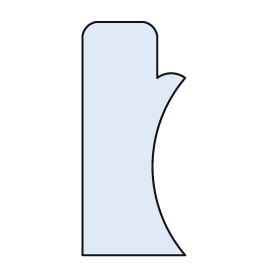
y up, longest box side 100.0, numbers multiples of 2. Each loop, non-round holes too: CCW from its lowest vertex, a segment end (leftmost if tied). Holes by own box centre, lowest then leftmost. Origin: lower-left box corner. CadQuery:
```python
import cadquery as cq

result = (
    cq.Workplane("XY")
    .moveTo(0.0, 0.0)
    .lineTo(44.0, 0.0)
    .threePointArc((30.0, 38.0), (44.0, 76.0))
    .threePointArc((38.0, 78.0), (32.0, 76.0))
    .lineTo(32.0, 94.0)
    .threePointArc((30.0, 98.0), (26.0, 100.0))
    .lineTo(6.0, 100.0)
    .threePointArc((2.0, 98.0), (0.0, 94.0))
    .close()
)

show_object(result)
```